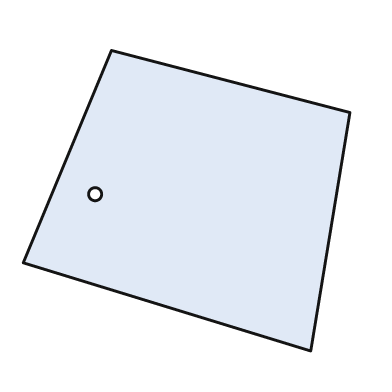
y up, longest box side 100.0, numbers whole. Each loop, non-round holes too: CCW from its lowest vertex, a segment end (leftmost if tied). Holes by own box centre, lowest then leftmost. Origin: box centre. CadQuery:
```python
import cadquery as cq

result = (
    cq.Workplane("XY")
    .moveTo(38.0, -46.0)
    .lineTo(50.0, 27.0)
    .lineTo(-23.0, 46.0)
    .lineTo(-50.0, -19.0)
    .close()
    .moveTo(-28.0, 2.0)
    .circle(2.0)
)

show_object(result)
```